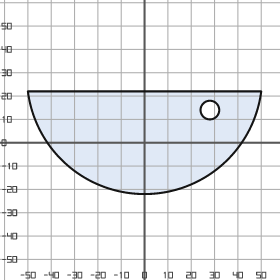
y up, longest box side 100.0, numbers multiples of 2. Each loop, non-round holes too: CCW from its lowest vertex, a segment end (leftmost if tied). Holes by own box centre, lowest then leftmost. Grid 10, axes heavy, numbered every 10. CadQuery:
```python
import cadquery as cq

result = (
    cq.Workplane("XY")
    .moveTo(-50.0, 22.0)
    .threePointArc((0.0, -22.0), (50.0, 22.0))
    .close()
    .moveTo(28.0, 14.0)
    .circle(4.0)
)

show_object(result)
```